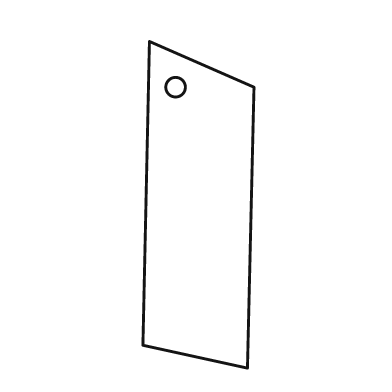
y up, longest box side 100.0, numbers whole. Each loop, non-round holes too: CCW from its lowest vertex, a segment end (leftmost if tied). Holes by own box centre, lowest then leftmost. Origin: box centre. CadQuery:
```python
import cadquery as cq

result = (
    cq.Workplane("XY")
    .moveTo(15.0, -50.0)
    .lineTo(17.0, 36.0)
    .lineTo(-15.0, 50.0)
    .lineTo(-17.0, -43.0)
    .close()
    .moveTo(-7.0, 36.0)
    .circle(3.0)
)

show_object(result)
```